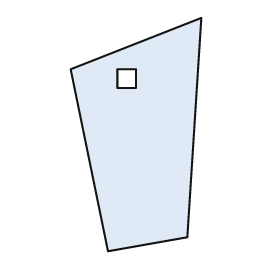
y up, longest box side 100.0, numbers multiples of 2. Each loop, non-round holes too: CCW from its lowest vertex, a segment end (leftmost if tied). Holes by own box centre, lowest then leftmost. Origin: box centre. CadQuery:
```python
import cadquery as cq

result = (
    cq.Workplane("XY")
    .moveTo(-12.0, -50.0)
    .lineTo(22.0, -44.0)
    .lineTo(28.0, 50.0)
    .lineTo(-28.0, 28.0)
    .close()
    .moveTo(-8.0, 20.0)
    .lineTo(0.0, 20.0)
    .lineTo(0.0, 28.0)
    .lineTo(-8.0, 28.0)
    .close()
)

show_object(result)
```